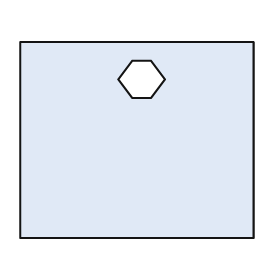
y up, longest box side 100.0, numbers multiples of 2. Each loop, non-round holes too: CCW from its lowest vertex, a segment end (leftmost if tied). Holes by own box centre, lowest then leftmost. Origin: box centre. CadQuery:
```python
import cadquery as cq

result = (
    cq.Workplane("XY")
    .moveTo(-50.0, -42.0)
    .lineTo(50.0, -42.0)
    .lineTo(50.0, 42.0)
    .lineTo(-50.0, 42.0)
    .close()
    .moveTo(-2.0, 18.0)
    .lineTo(6.0, 18.0)
    .lineTo(12.0, 26.0)
    .lineTo(6.0, 34.0)
    .lineTo(-2.0, 34.0)
    .lineTo(-8.0, 26.0)
    .close()
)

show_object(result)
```